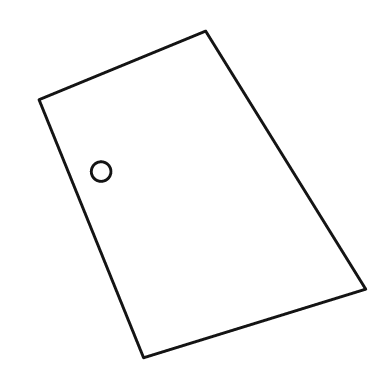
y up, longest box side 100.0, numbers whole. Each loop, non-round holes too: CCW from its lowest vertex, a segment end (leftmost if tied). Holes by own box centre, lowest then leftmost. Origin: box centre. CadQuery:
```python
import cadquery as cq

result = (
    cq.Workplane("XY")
    .moveTo(-18.0, -50.0)
    .lineTo(50.0, -29.0)
    .lineTo(1.0, 50.0)
    .lineTo(-50.0, 29.0)
    .close()
    .moveTo(-31.0, 7.0)
    .circle(3.0)
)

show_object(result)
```